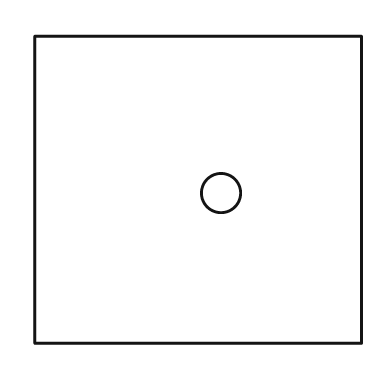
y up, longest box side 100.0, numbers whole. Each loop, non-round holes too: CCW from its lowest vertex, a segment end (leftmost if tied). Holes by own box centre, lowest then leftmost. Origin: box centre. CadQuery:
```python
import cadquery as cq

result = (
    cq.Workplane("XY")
    .moveTo(-50.0, -47.0)
    .lineTo(50.0, -47.0)
    .lineTo(50.0, 47.0)
    .lineTo(-50.0, 47.0)
    .close()
    .moveTo(7.0, -1.0)
    .circle(6.0)
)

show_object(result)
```